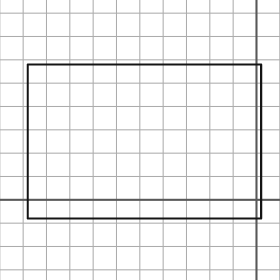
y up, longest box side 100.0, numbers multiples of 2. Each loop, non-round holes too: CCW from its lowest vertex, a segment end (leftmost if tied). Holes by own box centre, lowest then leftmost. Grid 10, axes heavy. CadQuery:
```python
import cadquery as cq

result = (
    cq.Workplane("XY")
    .moveTo(-98.0, -8.0)
    .lineTo(2.0, -8.0)
    .lineTo(2.0, 58.0)
    .lineTo(-98.0, 58.0)
    .close()
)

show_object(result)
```